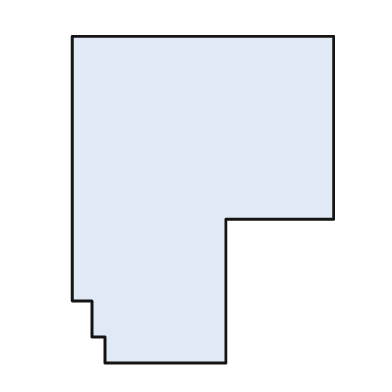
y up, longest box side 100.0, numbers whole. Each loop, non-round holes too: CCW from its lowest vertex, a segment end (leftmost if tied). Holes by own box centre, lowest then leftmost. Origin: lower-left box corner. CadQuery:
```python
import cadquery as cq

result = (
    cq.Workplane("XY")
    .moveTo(10.0, 0.0)
    .lineTo(47.0, 0.0)
    .lineTo(47.0, 44.0)
    .lineTo(80.0, 44.0)
    .lineTo(80.0, 100.0)
    .lineTo(0.0, 100.0)
    .lineTo(0.0, 19.0)
    .lineTo(6.0, 19.0)
    .lineTo(6.0, 8.0)
    .lineTo(10.0, 8.0)
    .close()
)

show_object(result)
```